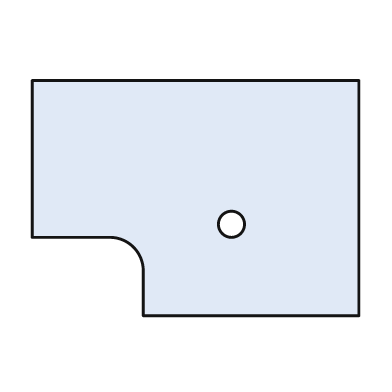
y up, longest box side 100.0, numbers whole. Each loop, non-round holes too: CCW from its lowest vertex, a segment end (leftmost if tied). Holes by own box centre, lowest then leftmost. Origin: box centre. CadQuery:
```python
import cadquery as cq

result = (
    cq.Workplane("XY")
    .moveTo(-16.0, -36.0)
    .lineTo(50.0, -36.0)
    .lineTo(50.0, 36.0)
    .lineTo(-50.0, 36.0)
    .lineTo(-50.0, -12.0)
    .lineTo(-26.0, -12.0)
    .threePointArc((-19.0, -15.0), (-16.0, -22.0))
    .close()
    .moveTo(11.0, -8.0)
    .circle(4.0)
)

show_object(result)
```